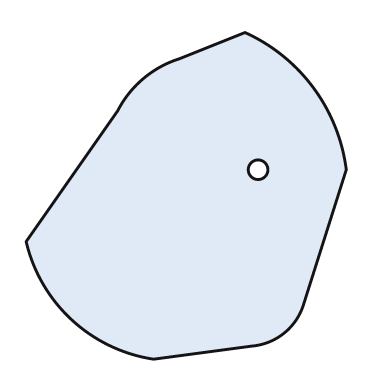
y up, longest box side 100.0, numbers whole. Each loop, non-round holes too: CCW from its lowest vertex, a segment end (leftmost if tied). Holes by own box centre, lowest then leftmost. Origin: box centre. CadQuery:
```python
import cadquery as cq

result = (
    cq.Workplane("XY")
    .moveTo(-10.0, -50.0)
    .lineTo(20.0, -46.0)
    .threePointArc((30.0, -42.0), (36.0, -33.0))
    .lineTo(49.0, 8.0)
    .threePointArc((39.0, 33.0), (18.0, 50.0))
    .lineTo(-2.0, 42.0)
    .threePointArc((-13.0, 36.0), (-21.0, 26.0))
    .lineTo(-49.0, -14.0)
    .threePointArc((-35.0, -38.0), (-10.0, -50.0))
    .close()
    .moveTo(22.0, 8.0)
    .circle(3.0)
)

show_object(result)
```